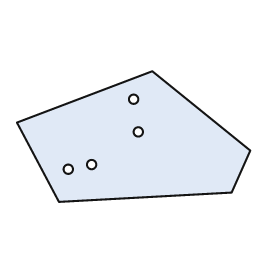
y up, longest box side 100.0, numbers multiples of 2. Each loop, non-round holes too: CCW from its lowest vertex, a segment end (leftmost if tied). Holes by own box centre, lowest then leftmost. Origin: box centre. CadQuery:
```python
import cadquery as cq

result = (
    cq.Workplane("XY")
    .moveTo(-32.0, -28.0)
    .lineTo(42.0, -24.0)
    .lineTo(50.0, -6.0)
    .lineTo(8.0, 28.0)
    .lineTo(-50.0, 6.0)
    .close()
    .moveTo(-28.0, -14.0)
    .circle(2.0)
    .moveTo(-18.0, -12.0)
    .circle(2.0)
    .moveTo(2.0, 2.0)
    .circle(2.0)
    .moveTo(0.0, 16.0)
    .circle(2.0)
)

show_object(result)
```